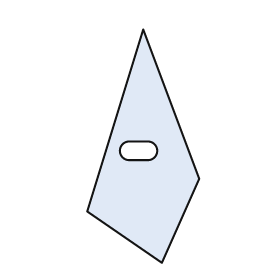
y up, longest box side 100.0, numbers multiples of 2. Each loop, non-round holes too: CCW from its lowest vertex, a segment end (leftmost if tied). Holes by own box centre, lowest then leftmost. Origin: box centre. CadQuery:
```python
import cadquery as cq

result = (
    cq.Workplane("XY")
    .moveTo(8.0, -50.0)
    .lineTo(24.0, -14.0)
    .lineTo(0.0, 50.0)
    .lineTo(-24.0, -28.0)
    .close()
    .moveTo(-6.0, -6.0)
    .lineTo(2.0, -6.0)
    .threePointArc((6.0, -2.0), (2.0, 2.0))
    .lineTo(-6.0, 2.0)
    .threePointArc((-10.0, -2.0), (-6.0, -6.0))
    .close()
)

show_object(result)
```